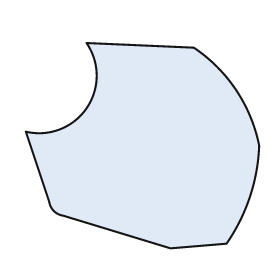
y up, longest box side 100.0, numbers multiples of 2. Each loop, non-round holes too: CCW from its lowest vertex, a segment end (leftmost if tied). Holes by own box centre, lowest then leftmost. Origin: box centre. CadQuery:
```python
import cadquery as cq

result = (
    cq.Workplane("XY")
    .moveTo(12.0, -44.0)
    .lineTo(36.0, -42.0)
    .threePointArc((46.0, -22.0), (50.0, 0.0))
    .threePointArc((40.0, 24.0), (22.0, 42.0))
    .lineTo(-24.0, 44.0)
    .threePointArc((-24.0, 16.0), (-50.0, 6.0))
    .lineTo(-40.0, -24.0)
    .threePointArc((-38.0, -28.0), (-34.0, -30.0))
    .close()
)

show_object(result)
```